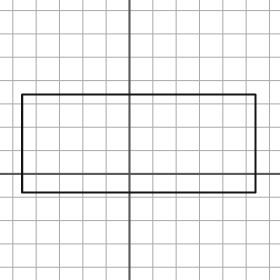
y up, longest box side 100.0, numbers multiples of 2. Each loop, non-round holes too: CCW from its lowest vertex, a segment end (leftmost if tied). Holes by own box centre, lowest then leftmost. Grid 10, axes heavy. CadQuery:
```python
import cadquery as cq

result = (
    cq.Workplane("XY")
    .moveTo(-46.0, -8.0)
    .lineTo(54.0, -8.0)
    .lineTo(54.0, 34.0)
    .lineTo(-46.0, 34.0)
    .close()
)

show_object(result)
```